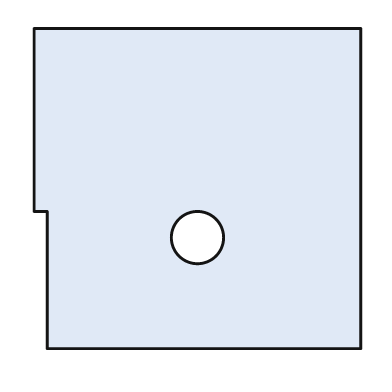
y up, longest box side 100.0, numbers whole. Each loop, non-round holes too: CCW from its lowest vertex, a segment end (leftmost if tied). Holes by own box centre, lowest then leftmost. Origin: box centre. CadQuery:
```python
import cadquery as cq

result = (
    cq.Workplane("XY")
    .moveTo(-46.0, -49.0)
    .lineTo(50.0, -49.0)
    .lineTo(50.0, 49.0)
    .lineTo(-50.0, 49.0)
    .lineTo(-50.0, -7.0)
    .lineTo(-46.0, -7.0)
    .close()
    .moveTo(0.0, -15.0)
    .circle(8.0)
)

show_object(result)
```